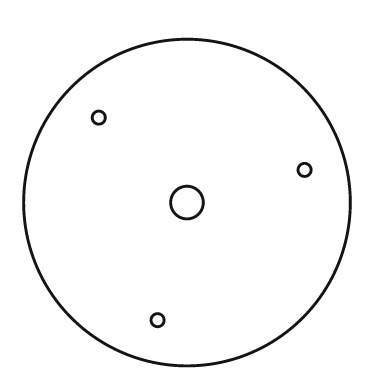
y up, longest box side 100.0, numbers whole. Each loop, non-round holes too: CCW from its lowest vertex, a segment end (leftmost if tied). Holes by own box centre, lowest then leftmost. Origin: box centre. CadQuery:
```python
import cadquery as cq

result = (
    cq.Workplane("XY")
    .moveTo(0.0, 0.0)
    .circle(50.0)
    .moveTo(-9.0, -36.0)
    .circle(2.0)
    .moveTo(0.0, 0.0)
    .circle(5.0)
    .moveTo(36.0, 10.0)
    .circle(2.0)
    .moveTo(-27.0, 26.0)
    .circle(2.0)
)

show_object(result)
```